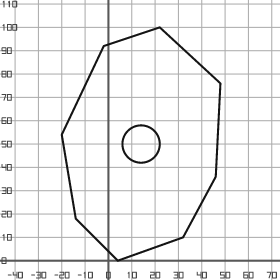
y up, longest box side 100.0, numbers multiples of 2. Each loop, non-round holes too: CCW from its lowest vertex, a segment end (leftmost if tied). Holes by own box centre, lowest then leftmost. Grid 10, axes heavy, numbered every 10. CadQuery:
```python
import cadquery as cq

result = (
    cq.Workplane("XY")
    .moveTo(4.0, 0.0)
    .lineTo(32.0, 10.0)
    .lineTo(46.0, 36.0)
    .lineTo(48.0, 76.0)
    .lineTo(22.0, 100.0)
    .lineTo(-2.0, 92.0)
    .lineTo(-20.0, 54.0)
    .lineTo(-14.0, 18.0)
    .close()
    .moveTo(14.0, 50.0)
    .circle(8.0)
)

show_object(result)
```